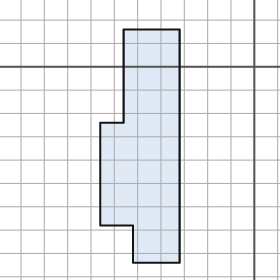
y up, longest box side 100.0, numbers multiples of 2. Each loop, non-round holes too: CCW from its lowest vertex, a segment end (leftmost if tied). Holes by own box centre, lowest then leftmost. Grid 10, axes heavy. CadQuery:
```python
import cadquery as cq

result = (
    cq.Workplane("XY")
    .moveTo(-52.0, -84.0)
    .lineTo(-32.0, -84.0)
    .lineTo(-32.0, 16.0)
    .lineTo(-56.0, 16.0)
    .lineTo(-56.0, -24.0)
    .lineTo(-66.0, -24.0)
    .lineTo(-66.0, -68.0)
    .lineTo(-52.0, -68.0)
    .close()
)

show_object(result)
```